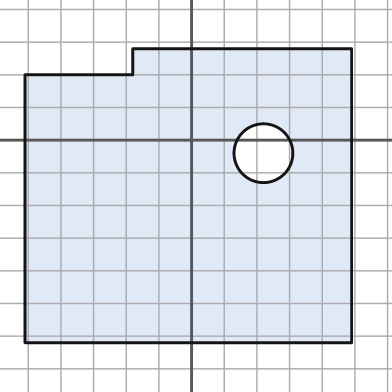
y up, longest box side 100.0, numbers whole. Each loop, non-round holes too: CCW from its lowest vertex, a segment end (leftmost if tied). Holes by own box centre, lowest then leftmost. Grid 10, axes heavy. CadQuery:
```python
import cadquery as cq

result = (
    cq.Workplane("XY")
    .moveTo(-51.0, -62.0)
    .lineTo(49.0, -62.0)
    .lineTo(49.0, 28.0)
    .lineTo(-18.0, 28.0)
    .lineTo(-18.0, 20.0)
    .lineTo(-51.0, 20.0)
    .close()
    .moveTo(22.0, -4.0)
    .circle(9.0)
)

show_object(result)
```